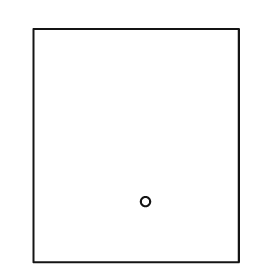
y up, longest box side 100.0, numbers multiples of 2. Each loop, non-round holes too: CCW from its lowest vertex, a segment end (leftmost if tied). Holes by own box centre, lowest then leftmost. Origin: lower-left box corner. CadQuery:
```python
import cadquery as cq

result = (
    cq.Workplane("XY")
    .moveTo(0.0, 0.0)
    .lineTo(88.0, 0.0)
    .lineTo(88.0, 100.0)
    .lineTo(0.0, 100.0)
    .close()
    .moveTo(48.0, 26.0)
    .circle(2.0)
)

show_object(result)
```